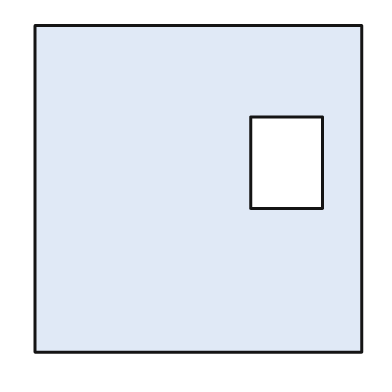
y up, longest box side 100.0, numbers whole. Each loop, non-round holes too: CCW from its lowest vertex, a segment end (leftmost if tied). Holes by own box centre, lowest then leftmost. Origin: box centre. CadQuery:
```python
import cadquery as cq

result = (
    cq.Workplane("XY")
    .moveTo(-50.0, -50.0)
    .lineTo(50.0, -50.0)
    .lineTo(50.0, 50.0)
    .lineTo(-50.0, 50.0)
    .close()
    .moveTo(16.0, -6.0)
    .lineTo(38.0, -6.0)
    .lineTo(38.0, 22.0)
    .lineTo(16.0, 22.0)
    .close()
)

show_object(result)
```